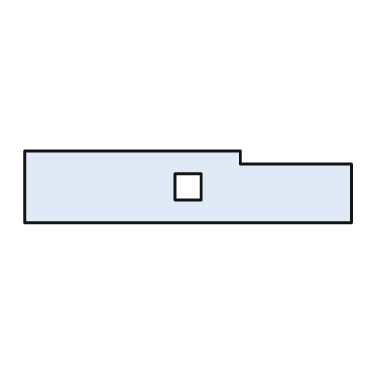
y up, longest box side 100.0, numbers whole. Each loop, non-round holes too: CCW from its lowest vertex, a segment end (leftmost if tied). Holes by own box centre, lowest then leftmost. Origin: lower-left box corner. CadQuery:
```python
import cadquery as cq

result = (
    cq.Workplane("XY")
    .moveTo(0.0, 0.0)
    .lineTo(100.0, 0.0)
    .lineTo(100.0, 18.0)
    .lineTo(66.0, 18.0)
    .lineTo(66.0, 22.0)
    .lineTo(0.0, 22.0)
    .close()
    .moveTo(46.0, 7.0)
    .lineTo(54.0, 7.0)
    .lineTo(54.0, 15.0)
    .lineTo(46.0, 15.0)
    .close()
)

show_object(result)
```